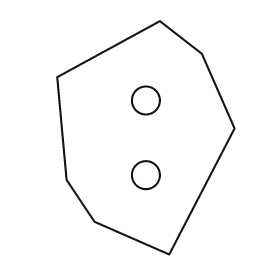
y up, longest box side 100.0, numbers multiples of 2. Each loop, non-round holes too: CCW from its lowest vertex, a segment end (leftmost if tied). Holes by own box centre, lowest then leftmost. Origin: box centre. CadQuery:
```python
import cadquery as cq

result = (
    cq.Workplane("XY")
    .moveTo(10.0, -50.0)
    .lineTo(38.0, 4.0)
    .lineTo(24.0, 36.0)
    .lineTo(6.0, 50.0)
    .lineTo(-38.0, 26.0)
    .lineTo(-34.0, -18.0)
    .lineTo(-22.0, -36.0)
    .close()
    .moveTo(0.0, -16.0)
    .circle(6.0)
    .moveTo(0.0, 16.0)
    .circle(6.0)
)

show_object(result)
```